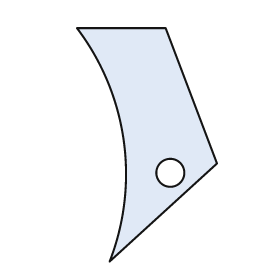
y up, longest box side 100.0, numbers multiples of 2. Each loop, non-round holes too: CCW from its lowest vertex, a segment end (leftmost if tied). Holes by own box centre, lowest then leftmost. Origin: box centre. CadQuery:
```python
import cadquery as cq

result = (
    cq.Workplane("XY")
    .moveTo(-16.0, -50.0)
    .lineTo(30.0, -8.0)
    .lineTo(8.0, 50.0)
    .lineTo(-30.0, 50.0)
    .threePointArc((-10.0, 2.0), (-16.0, -50.0))
    .close()
    .moveTo(10.0, -12.0)
    .circle(6.0)
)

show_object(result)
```